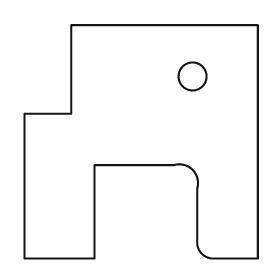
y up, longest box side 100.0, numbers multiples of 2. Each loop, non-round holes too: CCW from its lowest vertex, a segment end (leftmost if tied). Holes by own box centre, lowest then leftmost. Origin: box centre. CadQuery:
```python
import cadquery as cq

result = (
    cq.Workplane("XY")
    .moveTo(-50.0, -50.0)
    .lineTo(-20.0, -50.0)
    .lineTo(-20.0, -10.0)
    .lineTo(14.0, -10.0)
    .threePointArc((22.0, -12.0), (24.0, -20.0))
    .lineTo(24.0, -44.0)
    .threePointArc((26.0, -48.0), (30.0, -50.0))
    .lineTo(50.0, -50.0)
    .lineTo(50.0, 50.0)
    .lineTo(-30.0, 50.0)
    .lineTo(-30.0, 12.0)
    .lineTo(-50.0, 12.0)
    .close()
    .moveTo(22.0, 28.0)
    .circle(6.0)
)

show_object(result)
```